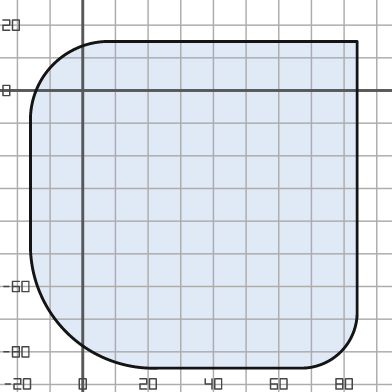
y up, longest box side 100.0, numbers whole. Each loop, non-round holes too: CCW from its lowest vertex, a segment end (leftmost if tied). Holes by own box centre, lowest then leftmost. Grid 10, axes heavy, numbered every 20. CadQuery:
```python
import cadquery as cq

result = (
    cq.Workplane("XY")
    .moveTo(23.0, -85.0)
    .lineTo(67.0, -85.0)
    .threePointArc((79.0, -80.0), (84.0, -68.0))
    .lineTo(84.0, 15.0)
    .lineTo(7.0, 15.0)
    .threePointArc((-9.0, 8.0), (-16.0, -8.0))
    .lineTo(-16.0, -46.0)
    .threePointArc((-5.0, -74.0), (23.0, -85.0))
    .close()
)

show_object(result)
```